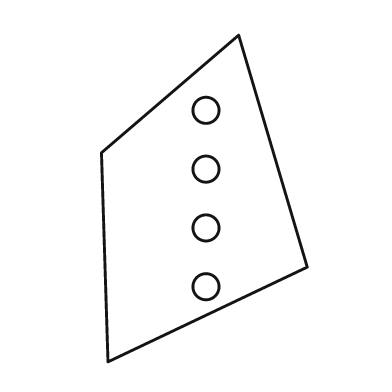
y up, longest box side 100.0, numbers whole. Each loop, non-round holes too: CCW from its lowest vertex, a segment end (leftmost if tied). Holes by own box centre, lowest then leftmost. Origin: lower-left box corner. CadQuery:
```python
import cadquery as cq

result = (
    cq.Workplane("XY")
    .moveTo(2.0, 0.0)
    .lineTo(63.0, 29.0)
    .lineTo(42.0, 100.0)
    .lineTo(0.0, 64.0)
    .close()
    .moveTo(32.0, 23.0)
    .circle(4.0)
    .moveTo(32.0, 41.0)
    .circle(4.0)
    .moveTo(32.0, 59.0)
    .circle(4.0)
    .moveTo(32.0, 77.0)
    .circle(4.0)
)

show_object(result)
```